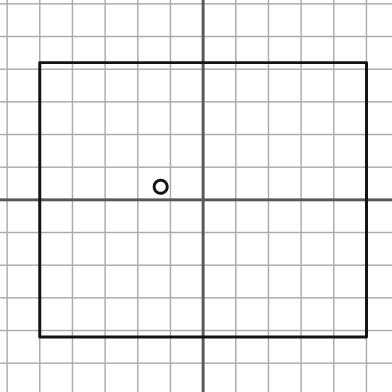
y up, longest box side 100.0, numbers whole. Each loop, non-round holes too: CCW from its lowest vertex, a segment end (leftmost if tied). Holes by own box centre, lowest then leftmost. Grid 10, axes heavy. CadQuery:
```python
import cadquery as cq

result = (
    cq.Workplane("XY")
    .moveTo(-50.0, -42.0)
    .lineTo(50.0, -42.0)
    .lineTo(50.0, 42.0)
    .lineTo(-50.0, 42.0)
    .close()
    .moveTo(-13.0, 4.0)
    .circle(2.0)
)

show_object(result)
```